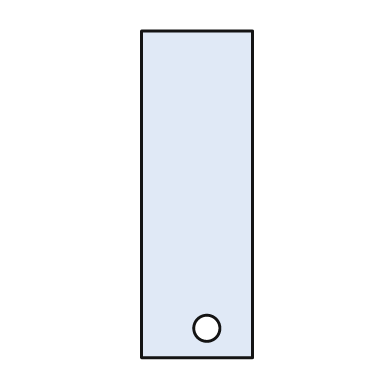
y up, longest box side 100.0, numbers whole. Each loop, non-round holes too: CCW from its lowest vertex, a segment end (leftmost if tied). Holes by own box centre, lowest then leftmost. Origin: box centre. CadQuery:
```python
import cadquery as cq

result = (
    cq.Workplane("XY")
    .moveTo(-17.0, -50.0)
    .lineTo(17.0, -50.0)
    .lineTo(17.0, 50.0)
    .lineTo(-17.0, 50.0)
    .close()
    .moveTo(3.0, -41.0)
    .circle(4.0)
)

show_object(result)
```